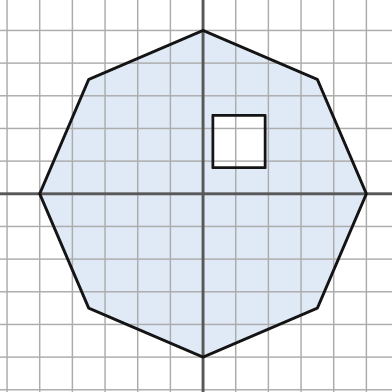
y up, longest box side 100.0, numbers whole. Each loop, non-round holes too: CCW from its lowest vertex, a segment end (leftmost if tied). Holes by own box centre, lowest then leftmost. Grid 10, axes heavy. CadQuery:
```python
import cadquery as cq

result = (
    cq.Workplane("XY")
    .moveTo(0.0, -50.0)
    .lineTo(35.0, -35.0)
    .lineTo(50.0, 0.0)
    .lineTo(35.0, 35.0)
    .lineTo(0.0, 50.0)
    .lineTo(-35.0, 35.0)
    .lineTo(-50.0, 0.0)
    .lineTo(-35.0, -35.0)
    .close()
    .moveTo(3.0, 8.0)
    .lineTo(19.0, 8.0)
    .lineTo(19.0, 24.0)
    .lineTo(3.0, 24.0)
    .close()
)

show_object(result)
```